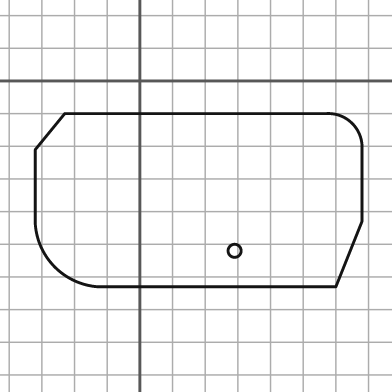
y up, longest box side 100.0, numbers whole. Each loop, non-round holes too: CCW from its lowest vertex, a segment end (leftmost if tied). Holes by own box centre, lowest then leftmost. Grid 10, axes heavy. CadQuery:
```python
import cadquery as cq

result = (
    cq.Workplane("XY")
    .moveTo(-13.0, -63.0)
    .lineTo(60.0, -63.0)
    .lineTo(68.0, -43.0)
    .lineTo(68.0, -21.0)
    .threePointArc((65.0, -13.0), (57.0, -10.0))
    .lineTo(-23.0, -10.0)
    .lineTo(-32.0, -21.0)
    .lineTo(-32.0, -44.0)
    .threePointArc((-26.0, -57.0), (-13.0, -63.0))
    .close()
    .moveTo(29.0, -52.0)
    .circle(2.0)
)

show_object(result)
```